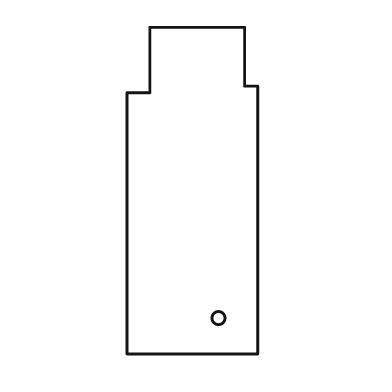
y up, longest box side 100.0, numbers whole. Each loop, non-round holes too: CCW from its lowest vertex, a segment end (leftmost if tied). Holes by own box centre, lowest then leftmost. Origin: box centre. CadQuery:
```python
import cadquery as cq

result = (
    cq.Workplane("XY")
    .moveTo(-20.0, -50.0)
    .lineTo(20.0, -50.0)
    .lineTo(20.0, 32.0)
    .lineTo(16.0, 32.0)
    .lineTo(16.0, 50.0)
    .lineTo(-13.0, 50.0)
    .lineTo(-13.0, 30.0)
    .lineTo(-20.0, 30.0)
    .close()
    .moveTo(8.0, -39.0)
    .circle(2.0)
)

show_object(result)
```